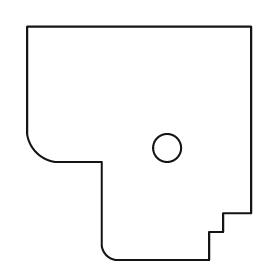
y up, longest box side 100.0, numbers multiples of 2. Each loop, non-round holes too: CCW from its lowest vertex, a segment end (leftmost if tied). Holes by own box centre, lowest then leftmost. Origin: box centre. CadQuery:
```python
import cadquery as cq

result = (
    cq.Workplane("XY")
    .moveTo(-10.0, -50.0)
    .lineTo(30.0, -50.0)
    .lineTo(30.0, -38.0)
    .lineTo(36.0, -38.0)
    .lineTo(36.0, -30.0)
    .lineTo(48.0, -30.0)
    .lineTo(48.0, 50.0)
    .lineTo(-48.0, 50.0)
    .lineTo(-48.0, 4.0)
    .threePointArc((-44.0, -4.0), (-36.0, -8.0))
    .lineTo(-16.0, -8.0)
    .lineTo(-16.0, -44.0)
    .threePointArc((-14.0, -48.0), (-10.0, -50.0))
    .close()
    .moveTo(12.0, -2.0)
    .circle(6.0)
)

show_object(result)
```